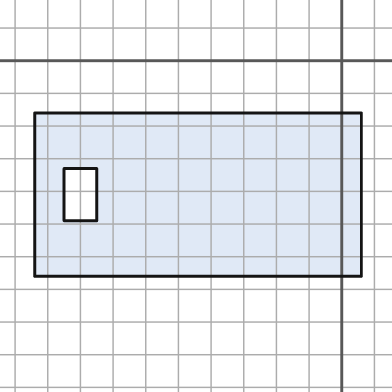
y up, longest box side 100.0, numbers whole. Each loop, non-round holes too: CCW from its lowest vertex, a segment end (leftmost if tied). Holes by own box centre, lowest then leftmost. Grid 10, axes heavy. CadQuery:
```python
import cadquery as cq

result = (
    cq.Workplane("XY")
    .moveTo(-94.0, -66.0)
    .lineTo(6.0, -66.0)
    .lineTo(6.0, -16.0)
    .lineTo(-94.0, -16.0)
    .close()
    .moveTo(-85.0, -49.0)
    .lineTo(-75.0, -49.0)
    .lineTo(-75.0, -33.0)
    .lineTo(-85.0, -33.0)
    .close()
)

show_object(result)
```